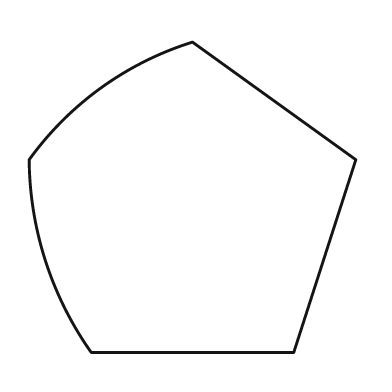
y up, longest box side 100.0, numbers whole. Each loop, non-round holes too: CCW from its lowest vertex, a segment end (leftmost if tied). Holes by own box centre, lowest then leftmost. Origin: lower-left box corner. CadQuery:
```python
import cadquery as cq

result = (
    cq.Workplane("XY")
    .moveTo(19.0, 0.0)
    .lineTo(81.0, 0.0)
    .lineTo(100.0, 59.0)
    .lineTo(50.0, 95.0)
    .threePointArc((22.0, 81.0), (0.0, 59.0))
    .threePointArc((5.0, 28.0), (19.0, 0.0))
    .close()
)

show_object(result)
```